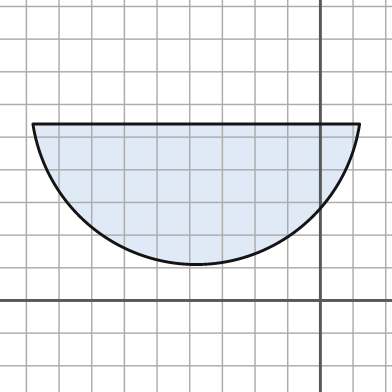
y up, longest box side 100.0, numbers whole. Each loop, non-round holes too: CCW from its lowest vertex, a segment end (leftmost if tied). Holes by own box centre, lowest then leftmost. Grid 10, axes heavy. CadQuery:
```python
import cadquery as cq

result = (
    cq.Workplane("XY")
    .moveTo(-88.0, 54.0)
    .threePointArc((-38.0, 11.0), (12.0, 54.0))
    .close()
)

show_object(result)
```